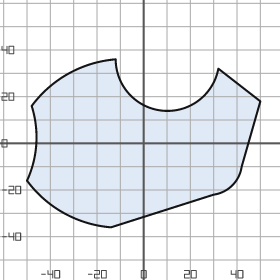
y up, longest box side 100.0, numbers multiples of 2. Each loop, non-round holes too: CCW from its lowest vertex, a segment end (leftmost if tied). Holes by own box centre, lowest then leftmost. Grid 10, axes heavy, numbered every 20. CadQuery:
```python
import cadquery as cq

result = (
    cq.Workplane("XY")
    .moveTo(-14.0, -36.0)
    .lineTo(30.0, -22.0)
    .threePointArc((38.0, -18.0), (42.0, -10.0))
    .lineTo(50.0, 18.0)
    .lineTo(32.0, 32.0)
    .threePointArc((8.0, 14.0), (-12.0, 36.0))
    .threePointArc((-32.0, 30.0), (-48.0, 16.0))
    .threePointArc((-46.0, 0.0), (-50.0, -16.0))
    .threePointArc((-34.0, -30.0), (-14.0, -36.0))
    .close()
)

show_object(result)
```